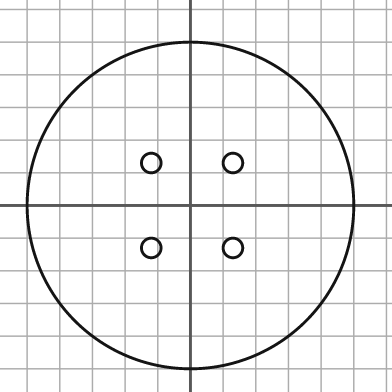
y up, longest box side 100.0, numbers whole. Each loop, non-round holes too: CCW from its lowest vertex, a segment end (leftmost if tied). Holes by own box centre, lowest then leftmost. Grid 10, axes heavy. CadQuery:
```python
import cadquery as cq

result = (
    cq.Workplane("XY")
    .moveTo(0.0, 0.0)
    .circle(50.0)
    .moveTo(-12.0, -13.0)
    .circle(3.0)
    .moveTo(13.0, -13.0)
    .circle(3.0)
    .moveTo(-12.0, 13.0)
    .circle(3.0)
    .moveTo(13.0, 13.0)
    .circle(3.0)
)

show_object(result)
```